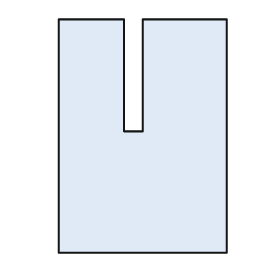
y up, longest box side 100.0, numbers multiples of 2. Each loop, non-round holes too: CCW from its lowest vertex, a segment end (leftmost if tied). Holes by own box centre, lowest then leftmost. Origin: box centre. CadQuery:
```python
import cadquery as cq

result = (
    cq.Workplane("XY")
    .moveTo(-36.0, -50.0)
    .lineTo(36.0, -50.0)
    .lineTo(36.0, 50.0)
    .lineTo(0.0, 50.0)
    .lineTo(0.0, 2.0)
    .lineTo(-8.0, 2.0)
    .lineTo(-8.0, 50.0)
    .lineTo(-36.0, 50.0)
    .close()
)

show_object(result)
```